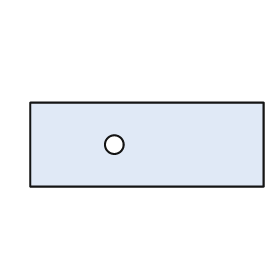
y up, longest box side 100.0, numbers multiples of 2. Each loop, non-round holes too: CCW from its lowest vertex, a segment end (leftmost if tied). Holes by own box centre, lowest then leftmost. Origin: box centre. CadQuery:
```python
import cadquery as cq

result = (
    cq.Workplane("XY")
    .moveTo(-50.0, -18.0)
    .lineTo(50.0, -18.0)
    .lineTo(50.0, 18.0)
    .lineTo(-50.0, 18.0)
    .close()
    .moveTo(-14.0, 0.0)
    .circle(4.0)
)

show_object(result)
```